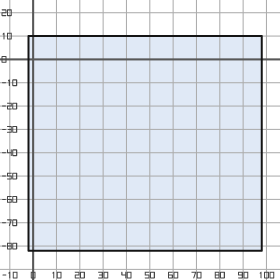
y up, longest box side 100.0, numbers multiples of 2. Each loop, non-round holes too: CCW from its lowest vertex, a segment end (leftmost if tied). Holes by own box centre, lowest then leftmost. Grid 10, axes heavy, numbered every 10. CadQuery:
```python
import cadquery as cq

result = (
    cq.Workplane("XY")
    .moveTo(-2.0, -82.0)
    .lineTo(98.0, -82.0)
    .lineTo(98.0, 10.0)
    .lineTo(-2.0, 10.0)
    .close()
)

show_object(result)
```